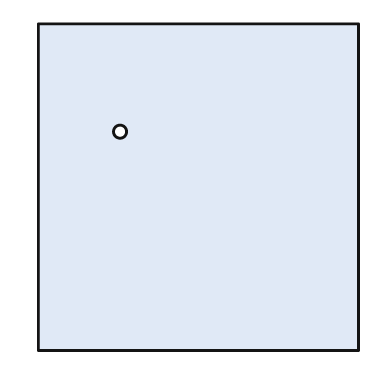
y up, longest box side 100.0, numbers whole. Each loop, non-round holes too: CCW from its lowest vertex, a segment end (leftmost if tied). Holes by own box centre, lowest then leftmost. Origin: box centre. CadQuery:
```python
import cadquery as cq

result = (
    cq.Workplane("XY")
    .moveTo(-49.0, -50.0)
    .lineTo(49.0, -50.0)
    .lineTo(49.0, 50.0)
    .lineTo(-49.0, 50.0)
    .close()
    .moveTo(-24.0, 17.0)
    .circle(2.0)
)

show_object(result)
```